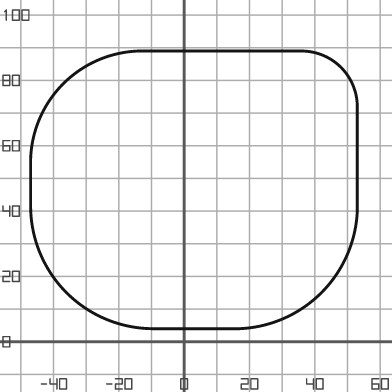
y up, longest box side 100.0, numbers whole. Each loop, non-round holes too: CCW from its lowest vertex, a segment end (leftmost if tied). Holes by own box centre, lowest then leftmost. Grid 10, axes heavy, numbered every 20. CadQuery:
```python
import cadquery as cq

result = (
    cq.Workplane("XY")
    .moveTo(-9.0, 4.0)
    .lineTo(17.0, 4.0)
    .threePointArc((42.0, 15.0), (53.0, 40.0))
    .lineTo(53.0, 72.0)
    .threePointArc((48.0, 84.0), (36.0, 89.0))
    .lineTo(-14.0, 89.0)
    .threePointArc((-37.0, 79.0), (-47.0, 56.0))
    .lineTo(-47.0, 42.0)
    .threePointArc((-36.0, 15.0), (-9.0, 4.0))
    .close()
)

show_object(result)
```